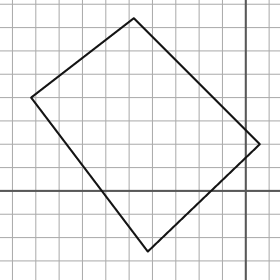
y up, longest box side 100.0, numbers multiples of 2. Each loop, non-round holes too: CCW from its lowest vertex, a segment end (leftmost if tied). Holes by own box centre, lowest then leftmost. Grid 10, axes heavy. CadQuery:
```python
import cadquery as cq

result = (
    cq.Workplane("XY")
    .moveTo(-42.0, -26.0)
    .lineTo(6.0, 20.0)
    .lineTo(-48.0, 74.0)
    .lineTo(-92.0, 40.0)
    .close()
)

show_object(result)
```